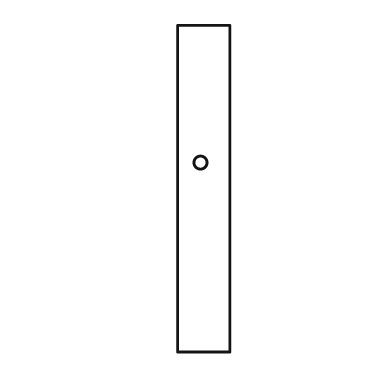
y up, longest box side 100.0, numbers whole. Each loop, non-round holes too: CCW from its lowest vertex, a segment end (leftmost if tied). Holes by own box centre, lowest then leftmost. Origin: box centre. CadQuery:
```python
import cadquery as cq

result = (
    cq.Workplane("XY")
    .moveTo(-8.0, -50.0)
    .lineTo(8.0, -50.0)
    .lineTo(8.0, 50.0)
    .lineTo(-8.0, 50.0)
    .close()
    .moveTo(-1.0, 8.0)
    .circle(2.0)
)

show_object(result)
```